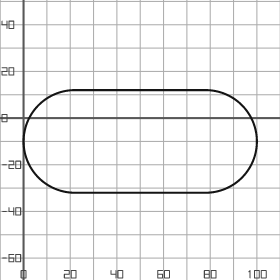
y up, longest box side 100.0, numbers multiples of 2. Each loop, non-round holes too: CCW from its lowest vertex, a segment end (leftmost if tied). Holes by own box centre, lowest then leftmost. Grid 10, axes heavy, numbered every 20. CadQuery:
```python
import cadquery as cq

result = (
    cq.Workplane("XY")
    .moveTo(22.0, -32.0)
    .lineTo(78.0, -32.0)
    .threePointArc((100.0, -10.0), (78.0, 12.0))
    .lineTo(22.0, 12.0)
    .threePointArc((0.0, -10.0), (22.0, -32.0))
    .close()
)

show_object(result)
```